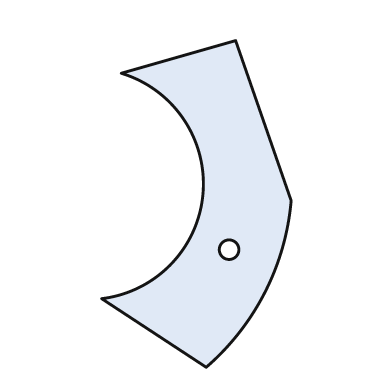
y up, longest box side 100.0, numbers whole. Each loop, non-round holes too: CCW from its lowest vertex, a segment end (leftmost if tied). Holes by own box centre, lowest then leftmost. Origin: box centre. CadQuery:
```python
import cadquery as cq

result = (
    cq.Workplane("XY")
    .moveTo(3.0, -50.0)
    .threePointArc((21.0, -27.0), (29.0, 1.0))
    .lineTo(12.0, 50.0)
    .lineTo(-23.0, 40.0)
    .threePointArc((2.0, 3.0), (-29.0, -29.0))
    .close()
    .moveTo(10.0, -14.0)
    .circle(3.0)
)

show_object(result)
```